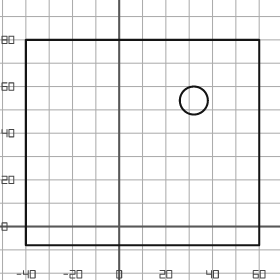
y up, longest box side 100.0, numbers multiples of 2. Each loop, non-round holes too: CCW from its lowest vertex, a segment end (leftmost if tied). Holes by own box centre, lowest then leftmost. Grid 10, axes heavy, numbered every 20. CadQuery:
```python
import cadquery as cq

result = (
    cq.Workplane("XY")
    .moveTo(-40.0, -8.0)
    .lineTo(60.0, -8.0)
    .lineTo(60.0, 80.0)
    .lineTo(-40.0, 80.0)
    .close()
    .moveTo(32.0, 54.0)
    .circle(6.0)
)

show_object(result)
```